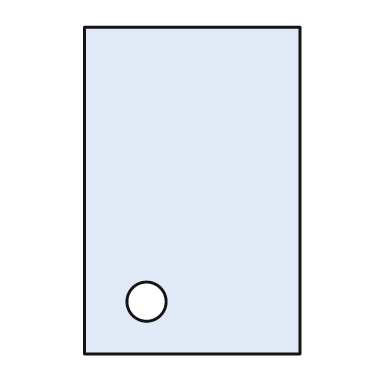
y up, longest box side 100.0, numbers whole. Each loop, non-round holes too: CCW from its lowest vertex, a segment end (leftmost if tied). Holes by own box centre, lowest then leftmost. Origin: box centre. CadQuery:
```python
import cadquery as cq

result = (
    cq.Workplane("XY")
    .moveTo(-33.0, -50.0)
    .lineTo(33.0, -50.0)
    .lineTo(33.0, 50.0)
    .lineTo(-33.0, 50.0)
    .close()
    .moveTo(-14.0, -34.0)
    .circle(6.0)
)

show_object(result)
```